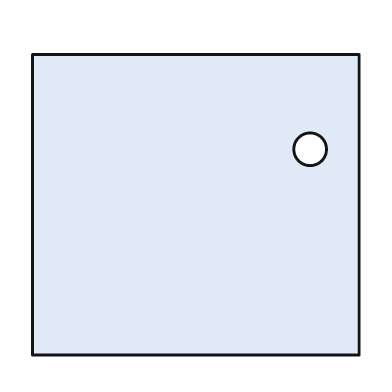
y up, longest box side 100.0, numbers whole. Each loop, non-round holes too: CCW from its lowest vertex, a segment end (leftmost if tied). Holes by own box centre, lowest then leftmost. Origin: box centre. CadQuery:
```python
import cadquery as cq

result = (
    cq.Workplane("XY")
    .moveTo(-50.0, -46.0)
    .lineTo(50.0, -46.0)
    .lineTo(50.0, 46.0)
    .lineTo(-50.0, 46.0)
    .close()
    .moveTo(35.0, 17.0)
    .circle(5.0)
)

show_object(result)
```